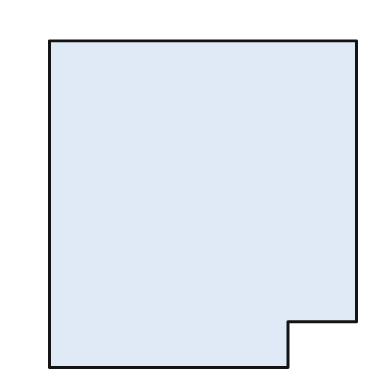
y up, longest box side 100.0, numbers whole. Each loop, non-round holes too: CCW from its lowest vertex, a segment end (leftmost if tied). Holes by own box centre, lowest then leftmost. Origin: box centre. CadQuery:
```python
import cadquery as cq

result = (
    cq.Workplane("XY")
    .moveTo(-47.0, -50.0)
    .lineTo(26.0, -50.0)
    .lineTo(26.0, -36.0)
    .lineTo(47.0, -36.0)
    .lineTo(47.0, 50.0)
    .lineTo(-47.0, 50.0)
    .close()
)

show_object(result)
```